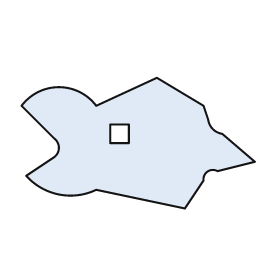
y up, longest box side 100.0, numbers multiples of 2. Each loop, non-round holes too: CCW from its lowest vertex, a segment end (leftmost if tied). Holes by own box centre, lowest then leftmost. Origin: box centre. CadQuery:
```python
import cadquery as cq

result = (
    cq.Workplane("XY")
    .moveTo(20.0, -28.0)
    .lineTo(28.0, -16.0)
    .threePointArc((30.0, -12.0), (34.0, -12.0))
    .lineTo(50.0, -8.0)
    .lineTo(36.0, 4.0)
    .threePointArc((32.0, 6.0), (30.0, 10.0))
    .lineTo(28.0, 16.0)
    .lineTo(8.0, 28.0)
    .lineTo(-18.0, 16.0)
    .threePointArc((-34.0, 24.0), (-50.0, 16.0))
    .lineTo(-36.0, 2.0)
    .threePointArc((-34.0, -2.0), (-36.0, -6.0))
    .lineTo(-48.0, -14.0)
    .threePointArc((-34.0, -22.0), (-18.0, -20.0))
    .close()
    .moveTo(-12.0, 0.0)
    .lineTo(-4.0, 0.0)
    .lineTo(-4.0, 8.0)
    .lineTo(-12.0, 8.0)
    .close()
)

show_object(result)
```